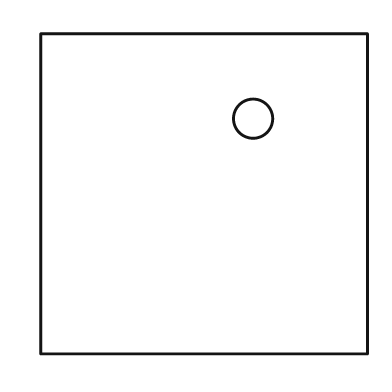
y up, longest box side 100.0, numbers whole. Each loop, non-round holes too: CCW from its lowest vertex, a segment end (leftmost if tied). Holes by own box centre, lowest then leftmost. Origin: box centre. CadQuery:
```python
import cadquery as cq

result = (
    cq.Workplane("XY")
    .moveTo(-50.0, -49.0)
    .lineTo(50.0, -49.0)
    .lineTo(50.0, 49.0)
    .lineTo(-50.0, 49.0)
    .close()
    .moveTo(15.0, 23.0)
    .circle(6.0)
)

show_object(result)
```